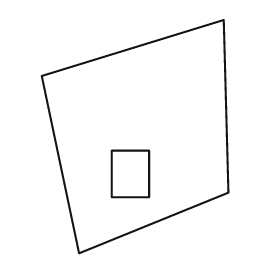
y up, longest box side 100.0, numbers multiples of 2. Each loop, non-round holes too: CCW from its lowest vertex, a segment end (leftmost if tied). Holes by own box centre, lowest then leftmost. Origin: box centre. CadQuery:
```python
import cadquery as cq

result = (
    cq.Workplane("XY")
    .moveTo(-24.0, -50.0)
    .lineTo(40.0, -24.0)
    .lineTo(38.0, 50.0)
    .lineTo(-40.0, 26.0)
    .close()
    .moveTo(-10.0, -26.0)
    .lineTo(6.0, -26.0)
    .lineTo(6.0, -6.0)
    .lineTo(-10.0, -6.0)
    .close()
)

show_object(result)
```